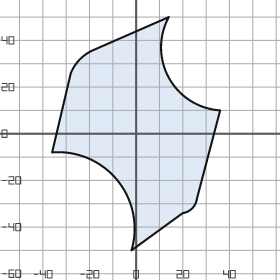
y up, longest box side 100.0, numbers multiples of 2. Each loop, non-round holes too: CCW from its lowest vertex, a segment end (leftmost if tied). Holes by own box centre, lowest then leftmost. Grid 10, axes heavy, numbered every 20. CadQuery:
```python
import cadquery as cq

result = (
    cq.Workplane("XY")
    .moveTo(-2.0, -50.0)
    .lineTo(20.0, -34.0)
    .threePointArc((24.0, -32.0), (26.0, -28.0))
    .lineTo(36.0, 10.0)
    .threePointArc((14.0, 24.0), (14.0, 50.0))
    .lineTo(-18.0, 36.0)
    .threePointArc((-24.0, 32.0), (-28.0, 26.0))
    .lineTo(-36.0, -8.0)
    .threePointArc((-8.0, -20.0), (-2.0, -50.0))
    .close()
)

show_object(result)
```